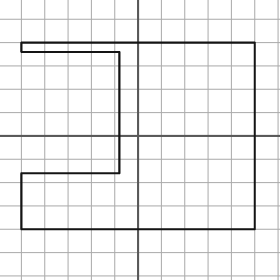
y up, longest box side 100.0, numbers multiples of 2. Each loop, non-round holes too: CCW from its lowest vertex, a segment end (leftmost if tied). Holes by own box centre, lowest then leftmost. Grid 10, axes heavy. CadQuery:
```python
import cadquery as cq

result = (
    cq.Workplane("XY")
    .moveTo(-50.0, -40.0)
    .lineTo(50.0, -40.0)
    .lineTo(50.0, 40.0)
    .lineTo(-50.0, 40.0)
    .lineTo(-50.0, 36.0)
    .lineTo(-8.0, 36.0)
    .lineTo(-8.0, -16.0)
    .lineTo(-50.0, -16.0)
    .close()
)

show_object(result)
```